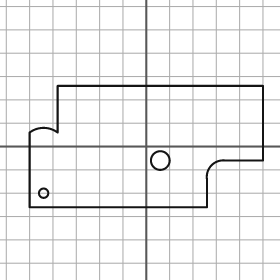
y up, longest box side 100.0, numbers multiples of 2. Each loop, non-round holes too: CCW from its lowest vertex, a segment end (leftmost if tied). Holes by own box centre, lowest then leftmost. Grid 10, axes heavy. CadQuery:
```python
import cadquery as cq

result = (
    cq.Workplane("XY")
    .moveTo(-50.0, -26.0)
    .lineTo(26.0, -26.0)
    .lineTo(26.0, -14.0)
    .threePointArc((28.0, -8.0), (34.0, -6.0))
    .lineTo(50.0, -6.0)
    .lineTo(50.0, 26.0)
    .lineTo(-38.0, 26.0)
    .lineTo(-38.0, 6.0)
    .threePointArc((-44.0, 8.0), (-50.0, 6.0))
    .close()
    .moveTo(-44.0, -20.0)
    .circle(2.0)
    .moveTo(6.0, -6.0)
    .circle(4.0)
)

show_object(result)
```